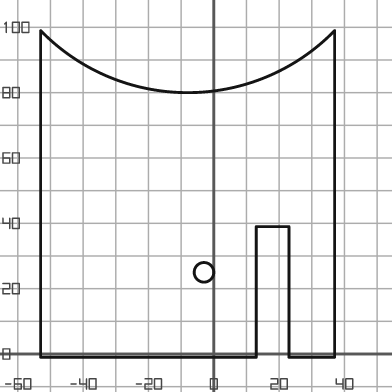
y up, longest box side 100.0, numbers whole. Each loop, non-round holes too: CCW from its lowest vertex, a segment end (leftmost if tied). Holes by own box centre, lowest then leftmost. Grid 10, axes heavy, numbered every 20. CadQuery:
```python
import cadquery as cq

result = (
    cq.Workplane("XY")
    .moveTo(-53.0, -1.0)
    .lineTo(13.0, -1.0)
    .lineTo(13.0, 39.0)
    .lineTo(23.0, 39.0)
    .lineTo(23.0, -1.0)
    .lineTo(37.0, -1.0)
    .lineTo(37.0, 99.0)
    .threePointArc((-8.0, 80.0), (-53.0, 99.0))
    .close()
    .moveTo(-3.0, 25.0)
    .circle(3.0)
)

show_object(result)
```